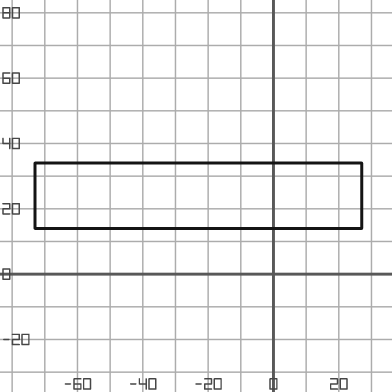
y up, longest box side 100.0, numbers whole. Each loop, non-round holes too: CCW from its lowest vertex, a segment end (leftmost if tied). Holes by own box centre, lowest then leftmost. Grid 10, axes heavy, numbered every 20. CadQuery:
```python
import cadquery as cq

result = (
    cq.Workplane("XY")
    .moveTo(-73.0, 14.0)
    .lineTo(27.0, 14.0)
    .lineTo(27.0, 34.0)
    .lineTo(-73.0, 34.0)
    .close()
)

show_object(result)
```